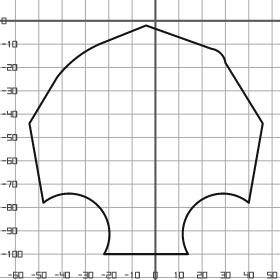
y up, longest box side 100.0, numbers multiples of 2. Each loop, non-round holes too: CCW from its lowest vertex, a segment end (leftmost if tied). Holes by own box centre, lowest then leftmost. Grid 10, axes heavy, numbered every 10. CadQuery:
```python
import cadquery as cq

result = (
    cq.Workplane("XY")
    .moveTo(-22.0, -100.0)
    .lineTo(14.0, -100.0)
    .threePointArc((18.0, -78.0), (40.0, -78.0))
    .lineTo(46.0, -44.0)
    .lineTo(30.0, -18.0)
    .threePointArc((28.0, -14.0), (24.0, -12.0))
    .lineTo(-4.0, -2.0)
    .lineTo(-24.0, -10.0)
    .threePointArc((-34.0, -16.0), (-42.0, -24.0))
    .lineTo(-54.0, -44.0)
    .lineTo(-48.0, -78.0)
    .threePointArc((-26.0, -78.0), (-22.0, -100.0))
    .close()
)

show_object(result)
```